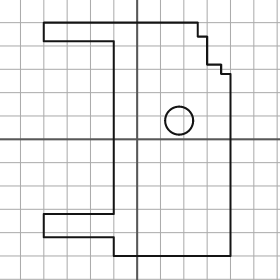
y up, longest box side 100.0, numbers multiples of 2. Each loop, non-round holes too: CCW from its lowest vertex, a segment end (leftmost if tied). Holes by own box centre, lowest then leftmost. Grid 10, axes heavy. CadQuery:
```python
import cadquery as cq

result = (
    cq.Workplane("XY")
    .moveTo(-10.0, -50.0)
    .lineTo(40.0, -50.0)
    .lineTo(40.0, 28.0)
    .lineTo(36.0, 28.0)
    .lineTo(36.0, 32.0)
    .lineTo(30.0, 32.0)
    .lineTo(30.0, 44.0)
    .lineTo(26.0, 44.0)
    .lineTo(26.0, 50.0)
    .lineTo(-40.0, 50.0)
    .lineTo(-40.0, 42.0)
    .lineTo(-10.0, 42.0)
    .lineTo(-10.0, -32.0)
    .lineTo(-40.0, -32.0)
    .lineTo(-40.0, -42.0)
    .lineTo(-10.0, -42.0)
    .close()
    .moveTo(18.0, 8.0)
    .circle(6.0)
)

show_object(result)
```